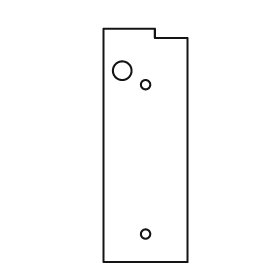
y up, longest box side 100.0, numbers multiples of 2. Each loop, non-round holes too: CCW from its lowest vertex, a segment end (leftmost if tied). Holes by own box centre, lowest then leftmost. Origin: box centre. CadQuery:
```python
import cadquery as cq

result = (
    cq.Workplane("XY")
    .moveTo(-18.0, -50.0)
    .lineTo(18.0, -50.0)
    .lineTo(18.0, 46.0)
    .lineTo(4.0, 46.0)
    .lineTo(4.0, 50.0)
    .lineTo(-18.0, 50.0)
    .close()
    .moveTo(0.0, -38.0)
    .circle(2.0)
    .moveTo(0.0, 26.0)
    .circle(2.0)
    .moveTo(-10.0, 32.0)
    .circle(4.0)
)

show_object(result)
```